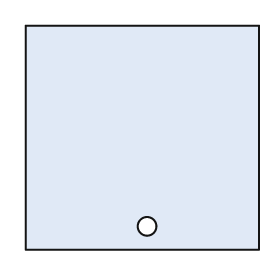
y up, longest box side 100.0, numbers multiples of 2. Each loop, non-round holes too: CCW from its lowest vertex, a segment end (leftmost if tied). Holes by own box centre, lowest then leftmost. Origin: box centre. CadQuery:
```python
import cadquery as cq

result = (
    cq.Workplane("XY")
    .moveTo(-50.0, -48.0)
    .lineTo(50.0, -48.0)
    .lineTo(50.0, 48.0)
    .lineTo(-50.0, 48.0)
    .close()
    .moveTo(2.0, -38.0)
    .circle(4.0)
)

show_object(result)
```